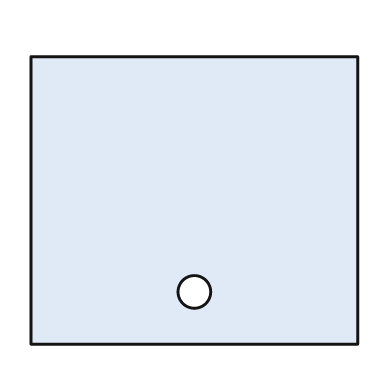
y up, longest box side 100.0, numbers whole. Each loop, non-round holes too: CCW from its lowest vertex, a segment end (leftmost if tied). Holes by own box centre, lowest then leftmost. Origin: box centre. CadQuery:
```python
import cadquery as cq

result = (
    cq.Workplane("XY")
    .moveTo(-50.0, -44.0)
    .lineTo(50.0, -44.0)
    .lineTo(50.0, 44.0)
    .lineTo(-50.0, 44.0)
    .close()
    .moveTo(0.0, -28.0)
    .circle(5.0)
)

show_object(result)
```